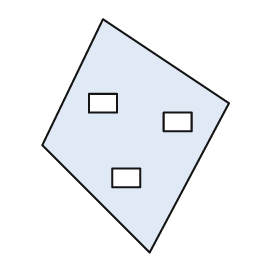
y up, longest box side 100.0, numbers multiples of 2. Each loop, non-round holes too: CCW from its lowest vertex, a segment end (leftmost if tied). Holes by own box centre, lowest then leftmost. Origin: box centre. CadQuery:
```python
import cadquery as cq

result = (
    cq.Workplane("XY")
    .moveTo(6.0, -50.0)
    .lineTo(40.0, 14.0)
    .lineTo(-14.0, 50.0)
    .lineTo(-40.0, -4.0)
    .close()
    .moveTo(-10.0, -22.0)
    .lineTo(2.0, -22.0)
    .lineTo(2.0, -14.0)
    .lineTo(-10.0, -14.0)
    .close()
    .moveTo(12.0, 2.0)
    .lineTo(24.0, 2.0)
    .lineTo(24.0, 10.0)
    .lineTo(12.0, 10.0)
    .close()
    .moveTo(-20.0, 10.0)
    .lineTo(-8.0, 10.0)
    .lineTo(-8.0, 18.0)
    .lineTo(-20.0, 18.0)
    .close()
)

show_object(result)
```